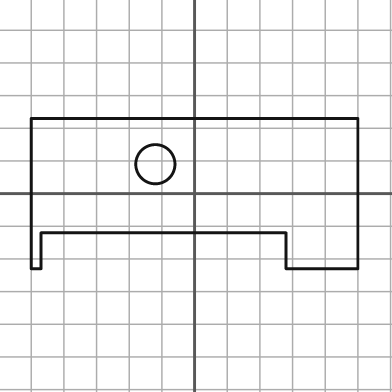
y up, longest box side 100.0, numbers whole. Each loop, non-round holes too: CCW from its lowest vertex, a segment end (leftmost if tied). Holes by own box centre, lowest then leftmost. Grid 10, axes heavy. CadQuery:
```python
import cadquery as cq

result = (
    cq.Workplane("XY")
    .moveTo(-50.0, -23.0)
    .lineTo(-47.0, -23.0)
    .lineTo(-47.0, -12.0)
    .lineTo(28.0, -12.0)
    .lineTo(28.0, -23.0)
    .lineTo(50.0, -23.0)
    .lineTo(50.0, 23.0)
    .lineTo(-50.0, 23.0)
    .close()
    .moveTo(-12.0, 9.0)
    .circle(6.0)
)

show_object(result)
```